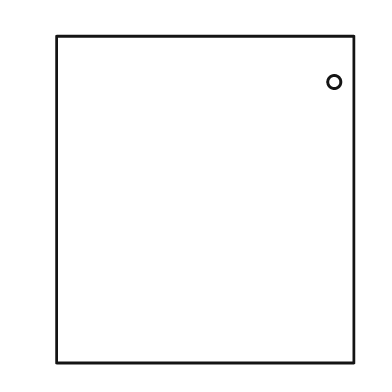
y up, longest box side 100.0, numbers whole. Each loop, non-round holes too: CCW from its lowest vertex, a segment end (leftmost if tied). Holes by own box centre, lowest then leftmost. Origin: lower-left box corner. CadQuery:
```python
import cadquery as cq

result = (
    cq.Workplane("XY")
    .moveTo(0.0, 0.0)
    .lineTo(91.0, 0.0)
    .lineTo(91.0, 100.0)
    .lineTo(0.0, 100.0)
    .close()
    .moveTo(85.0, 86.0)
    .circle(2.0)
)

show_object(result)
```